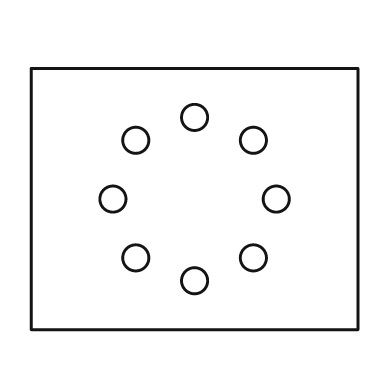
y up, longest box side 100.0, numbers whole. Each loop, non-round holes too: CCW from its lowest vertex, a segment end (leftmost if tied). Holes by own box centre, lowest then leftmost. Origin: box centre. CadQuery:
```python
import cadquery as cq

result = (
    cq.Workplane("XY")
    .moveTo(-50.0, -40.0)
    .lineTo(50.0, -40.0)
    .lineTo(50.0, 40.0)
    .lineTo(-50.0, 40.0)
    .close()
    .moveTo(0.0, -25.0)
    .circle(4.0)
    .moveTo(-18.0, -18.0)
    .circle(4.0)
    .moveTo(18.0, -18.0)
    .circle(4.0)
    .moveTo(-25.0, 0.0)
    .circle(4.0)
    .moveTo(25.0, 0.0)
    .circle(4.0)
    .moveTo(-18.0, 18.0)
    .circle(4.0)
    .moveTo(18.0, 18.0)
    .circle(4.0)
    .moveTo(0.0, 25.0)
    .circle(4.0)
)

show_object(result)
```